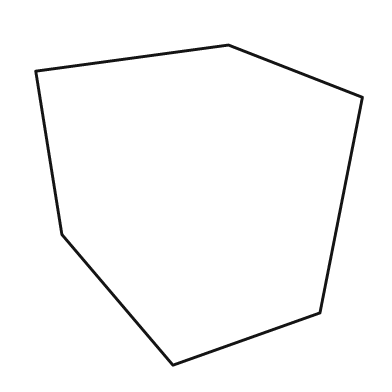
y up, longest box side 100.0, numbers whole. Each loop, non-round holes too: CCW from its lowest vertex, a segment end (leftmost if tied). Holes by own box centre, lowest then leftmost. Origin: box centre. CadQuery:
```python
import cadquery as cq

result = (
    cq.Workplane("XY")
    .moveTo(-8.0, -49.0)
    .lineTo(37.0, -33.0)
    .lineTo(50.0, 33.0)
    .lineTo(9.0, 49.0)
    .lineTo(-50.0, 41.0)
    .lineTo(-42.0, -9.0)
    .close()
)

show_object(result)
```